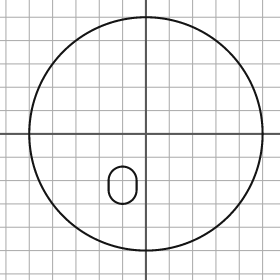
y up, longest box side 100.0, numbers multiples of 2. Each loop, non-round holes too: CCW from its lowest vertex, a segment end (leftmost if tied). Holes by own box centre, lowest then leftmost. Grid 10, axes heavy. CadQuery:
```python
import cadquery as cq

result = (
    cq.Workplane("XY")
    .moveTo(0.0, 0.0)
    .circle(50.0)
    .moveTo(-16.0, -24.0)
    .threePointArc((-10.0, -30.0), (-4.0, -24.0))
    .lineTo(-4.0, -20.0)
    .threePointArc((-10.0, -14.0), (-16.0, -20.0))
    .close()
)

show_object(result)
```